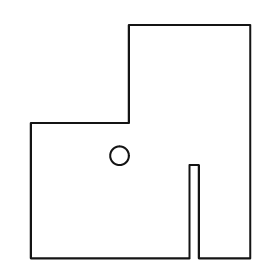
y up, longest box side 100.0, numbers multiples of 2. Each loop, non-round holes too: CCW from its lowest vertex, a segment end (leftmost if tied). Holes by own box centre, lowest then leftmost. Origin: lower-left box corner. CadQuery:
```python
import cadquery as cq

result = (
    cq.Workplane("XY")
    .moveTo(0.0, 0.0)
    .lineTo(68.0, 0.0)
    .lineTo(68.0, 40.0)
    .lineTo(72.0, 40.0)
    .lineTo(72.0, 0.0)
    .lineTo(94.0, 0.0)
    .lineTo(94.0, 100.0)
    .lineTo(42.0, 100.0)
    .lineTo(42.0, 58.0)
    .lineTo(0.0, 58.0)
    .close()
    .moveTo(38.0, 44.0)
    .circle(4.0)
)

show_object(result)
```